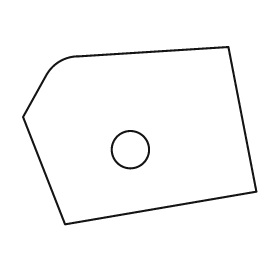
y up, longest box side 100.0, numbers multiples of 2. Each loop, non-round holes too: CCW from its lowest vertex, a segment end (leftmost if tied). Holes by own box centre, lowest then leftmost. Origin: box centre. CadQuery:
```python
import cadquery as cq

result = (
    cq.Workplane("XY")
    .moveTo(-32.0, -38.0)
    .lineTo(50.0, -24.0)
    .lineTo(38.0, 38.0)
    .lineTo(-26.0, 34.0)
    .threePointArc((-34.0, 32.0), (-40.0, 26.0))
    .lineTo(-50.0, 8.0)
    .close()
    .moveTo(-4.0, -6.0)
    .circle(8.0)
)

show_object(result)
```